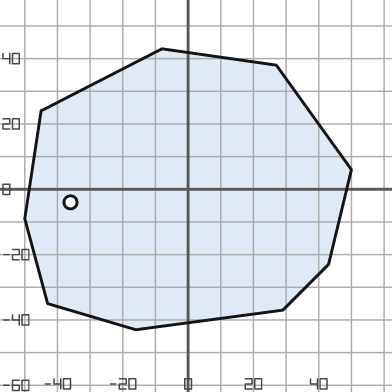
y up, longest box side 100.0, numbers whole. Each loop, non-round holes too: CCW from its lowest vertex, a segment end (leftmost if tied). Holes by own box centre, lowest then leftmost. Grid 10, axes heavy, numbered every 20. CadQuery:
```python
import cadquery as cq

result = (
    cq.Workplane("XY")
    .moveTo(-16.0, -43.0)
    .lineTo(29.0, -37.0)
    .lineTo(43.0, -23.0)
    .lineTo(50.0, 6.0)
    .lineTo(27.0, 38.0)
    .lineTo(-8.0, 43.0)
    .lineTo(-45.0, 24.0)
    .lineTo(-50.0, -9.0)
    .lineTo(-43.0, -35.0)
    .close()
    .moveTo(-36.0, -4.0)
    .circle(2.0)
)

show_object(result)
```